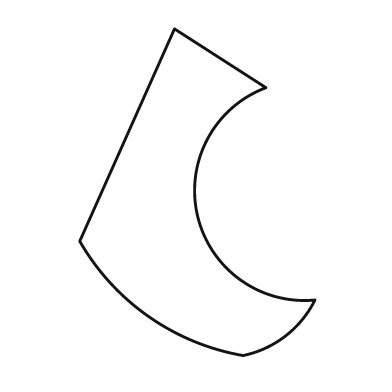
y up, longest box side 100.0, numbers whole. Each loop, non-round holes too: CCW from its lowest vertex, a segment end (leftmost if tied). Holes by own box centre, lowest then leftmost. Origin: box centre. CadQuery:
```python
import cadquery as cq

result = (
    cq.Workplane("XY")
    .moveTo(14.0, -50.0)
    .threePointArc((27.0, -44.0), (36.0, -33.0))
    .threePointArc((0.0, -7.0), (21.0, 32.0))
    .lineTo(-7.0, 50.0)
    .lineTo(-36.0, -15.0)
    .threePointArc((-15.0, -38.0), (14.0, -50.0))
    .close()
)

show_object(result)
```